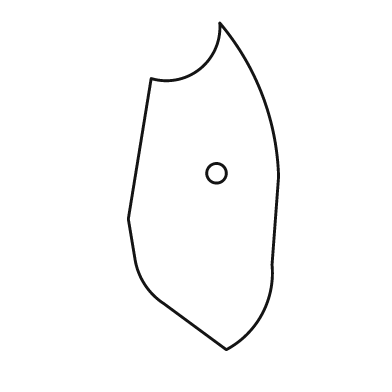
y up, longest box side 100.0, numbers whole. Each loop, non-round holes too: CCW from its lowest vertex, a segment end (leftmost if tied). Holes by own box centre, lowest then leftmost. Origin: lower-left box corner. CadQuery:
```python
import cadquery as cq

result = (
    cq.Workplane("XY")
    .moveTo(30.0, 0.0)
    .threePointArc((41.0, 11.0), (44.0, 26.0))
    .lineTo(46.0, 53.0)
    .threePointArc((41.0, 78.0), (28.0, 100.0))
    .threePointArc((22.0, 86.0), (7.0, 83.0))
    .lineTo(0.0, 40.0)
    .lineTo(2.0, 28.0)
    .threePointArc((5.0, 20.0), (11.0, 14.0))
    .close()
    .moveTo(27.0, 54.0)
    .circle(3.0)
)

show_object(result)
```